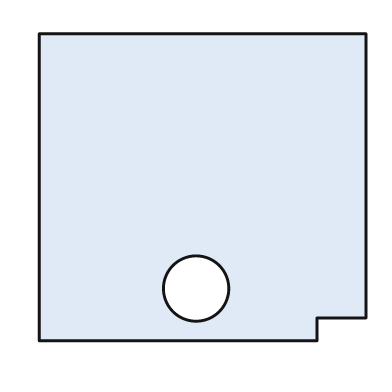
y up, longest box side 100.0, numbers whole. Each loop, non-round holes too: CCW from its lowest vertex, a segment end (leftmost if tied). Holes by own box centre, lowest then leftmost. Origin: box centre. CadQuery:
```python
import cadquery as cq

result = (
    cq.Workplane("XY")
    .moveTo(-50.0, -47.0)
    .lineTo(35.0, -47.0)
    .lineTo(35.0, -40.0)
    .lineTo(50.0, -40.0)
    .lineTo(50.0, 47.0)
    .lineTo(-50.0, 47.0)
    .close()
    .moveTo(-2.0, -31.0)
    .circle(10.0)
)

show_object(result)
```